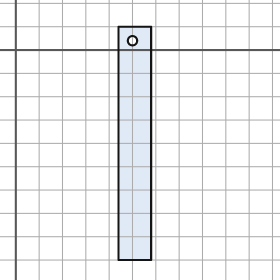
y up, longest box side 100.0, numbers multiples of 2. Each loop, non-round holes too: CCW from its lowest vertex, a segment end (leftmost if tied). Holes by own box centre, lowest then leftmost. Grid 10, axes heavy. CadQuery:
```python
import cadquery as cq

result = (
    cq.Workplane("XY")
    .moveTo(44.0, -90.0)
    .lineTo(58.0, -90.0)
    .lineTo(58.0, 10.0)
    .lineTo(44.0, 10.0)
    .close()
    .moveTo(50.0, 4.0)
    .circle(2.0)
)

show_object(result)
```